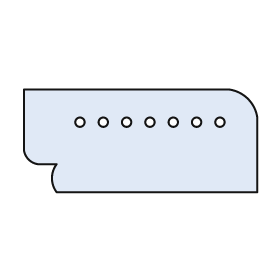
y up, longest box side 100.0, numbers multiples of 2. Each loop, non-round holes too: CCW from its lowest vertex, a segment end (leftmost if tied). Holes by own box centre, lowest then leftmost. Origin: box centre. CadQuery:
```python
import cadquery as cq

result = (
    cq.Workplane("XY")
    .moveTo(-36.0, -22.0)
    .lineTo(50.0, -22.0)
    .lineTo(50.0, 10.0)
    .threePointArc((46.0, 18.0), (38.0, 22.0))
    .lineTo(-50.0, 22.0)
    .lineTo(-50.0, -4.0)
    .threePointArc((-48.0, -8.0), (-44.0, -10.0))
    .lineTo(-36.0, -10.0)
    .threePointArc((-38.0, -16.0), (-36.0, -22.0))
    .close()
    .moveTo(-26.0, 8.0)
    .circle(2.0)
    .moveTo(-16.0, 8.0)
    .circle(2.0)
    .moveTo(-6.0, 8.0)
    .circle(2.0)
    .moveTo(4.0, 8.0)
    .circle(2.0)
    .moveTo(14.0, 8.0)
    .circle(2.0)
    .moveTo(24.0, 8.0)
    .circle(2.0)
    .moveTo(34.0, 8.0)
    .circle(2.0)
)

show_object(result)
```